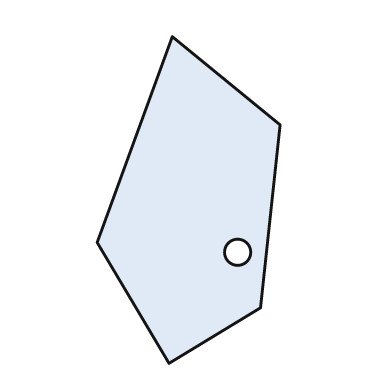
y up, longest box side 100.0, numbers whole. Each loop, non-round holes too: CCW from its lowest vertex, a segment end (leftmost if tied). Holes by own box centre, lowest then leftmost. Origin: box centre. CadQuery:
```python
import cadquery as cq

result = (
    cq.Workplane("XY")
    .moveTo(-6.0, -50.0)
    .lineTo(22.0, -33.0)
    .lineTo(28.0, 23.0)
    .lineTo(-5.0, 50.0)
    .lineTo(-28.0, -13.0)
    .close()
    .moveTo(15.0, -16.0)
    .circle(4.0)
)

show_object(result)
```